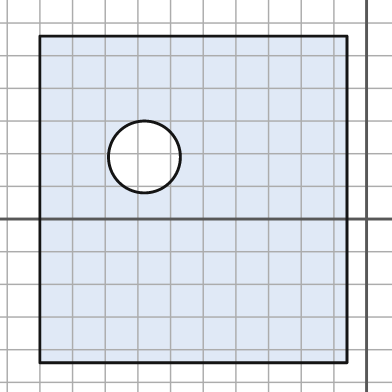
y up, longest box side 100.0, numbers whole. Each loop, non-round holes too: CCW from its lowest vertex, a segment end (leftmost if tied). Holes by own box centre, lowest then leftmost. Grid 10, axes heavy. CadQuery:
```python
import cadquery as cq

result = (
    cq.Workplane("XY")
    .moveTo(-100.0, -44.0)
    .lineTo(-6.0, -44.0)
    .lineTo(-6.0, 56.0)
    .lineTo(-100.0, 56.0)
    .close()
    .moveTo(-68.0, 19.0)
    .circle(11.0)
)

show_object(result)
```